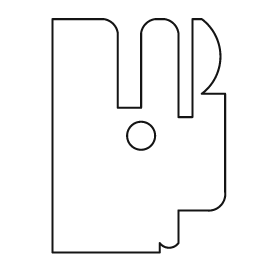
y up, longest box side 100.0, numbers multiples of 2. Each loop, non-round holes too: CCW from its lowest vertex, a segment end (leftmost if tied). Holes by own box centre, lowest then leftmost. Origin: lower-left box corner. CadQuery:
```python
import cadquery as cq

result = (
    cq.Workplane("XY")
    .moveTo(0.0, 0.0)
    .lineTo(46.0, 0.0)
    .lineTo(46.0, 4.0)
    .threePointArc((50.0, 2.0), (54.0, 4.0))
    .lineTo(54.0, 18.0)
    .lineTo(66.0, 18.0)
    .threePointArc((72.0, 20.0), (74.0, 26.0))
    .lineTo(74.0, 68.0)
    .lineTo(64.0, 68.0)
    .threePointArc((72.0, 84.0), (64.0, 100.0))
    .lineTo(60.0, 100.0)
    .lineTo(60.0, 58.0)
    .lineTo(54.0, 58.0)
    .lineTo(54.0, 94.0)
    .threePointArc((52.0, 98.0), (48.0, 100.0))
    .lineTo(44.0, 100.0)
    .threePointArc((40.0, 98.0), (38.0, 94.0))
    .lineTo(38.0, 62.0)
    .lineTo(28.0, 62.0)
    .lineTo(28.0, 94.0)
    .threePointArc((26.0, 98.0), (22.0, 100.0))
    .lineTo(0.0, 100.0)
    .close()
    .moveTo(38.0, 50.0)
    .circle(6.0)
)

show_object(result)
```